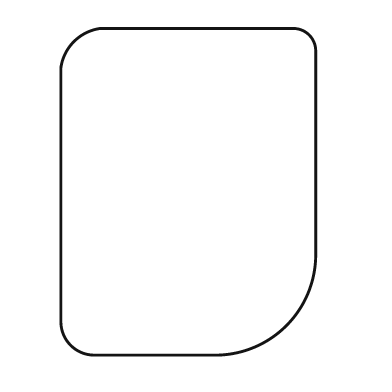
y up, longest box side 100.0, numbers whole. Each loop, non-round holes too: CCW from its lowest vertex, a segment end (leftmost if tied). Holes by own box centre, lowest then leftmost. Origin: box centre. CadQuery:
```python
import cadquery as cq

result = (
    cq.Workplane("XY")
    .moveTo(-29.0, -50.0)
    .lineTo(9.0, -50.0)
    .threePointArc((30.0, -41.0), (39.0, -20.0))
    .lineTo(39.0, 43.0)
    .threePointArc((37.0, 48.0), (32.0, 50.0))
    .lineTo(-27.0, 50.0)
    .threePointArc((-35.0, 46.0), (-39.0, 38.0))
    .lineTo(-39.0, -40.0)
    .threePointArc((-36.0, -47.0), (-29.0, -50.0))
    .close()
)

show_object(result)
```